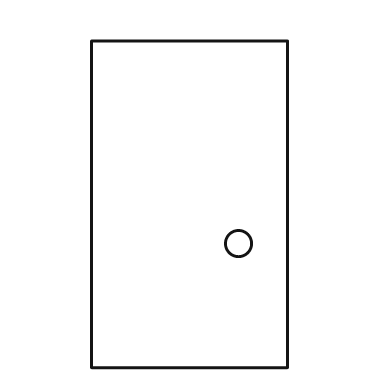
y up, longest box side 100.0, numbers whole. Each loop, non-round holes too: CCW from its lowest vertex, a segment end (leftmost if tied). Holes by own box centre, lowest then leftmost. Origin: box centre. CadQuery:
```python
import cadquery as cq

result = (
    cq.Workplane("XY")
    .moveTo(-30.0, -50.0)
    .lineTo(30.0, -50.0)
    .lineTo(30.0, 50.0)
    .lineTo(-30.0, 50.0)
    .close()
    .moveTo(15.0, -12.0)
    .circle(4.0)
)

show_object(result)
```